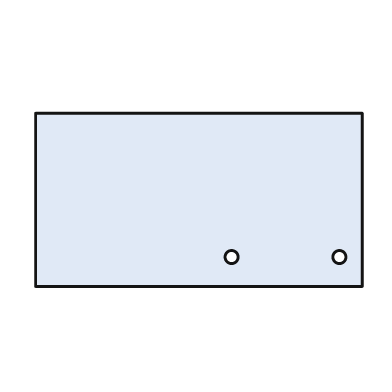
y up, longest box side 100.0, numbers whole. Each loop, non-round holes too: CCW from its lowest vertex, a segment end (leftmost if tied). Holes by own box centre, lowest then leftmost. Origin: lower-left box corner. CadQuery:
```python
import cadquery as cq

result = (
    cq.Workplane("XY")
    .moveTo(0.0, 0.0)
    .lineTo(100.0, 0.0)
    .lineTo(100.0, 53.0)
    .lineTo(0.0, 53.0)
    .close()
    .moveTo(60.0, 9.0)
    .circle(2.0)
    .moveTo(93.0, 9.0)
    .circle(2.0)
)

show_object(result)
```